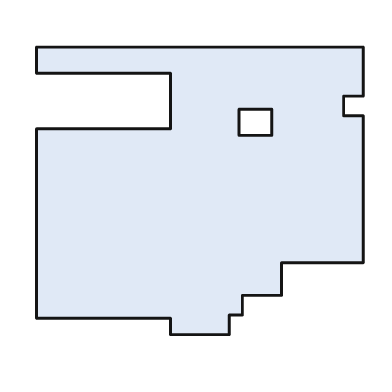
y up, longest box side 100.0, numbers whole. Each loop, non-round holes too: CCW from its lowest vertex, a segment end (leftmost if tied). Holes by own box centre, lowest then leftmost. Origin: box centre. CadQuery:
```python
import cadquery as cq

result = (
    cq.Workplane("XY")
    .moveTo(-9.0, -44.0)
    .lineTo(9.0, -44.0)
    .lineTo(9.0, -38.0)
    .lineTo(13.0, -38.0)
    .lineTo(13.0, -32.0)
    .lineTo(25.0, -32.0)
    .lineTo(25.0, -22.0)
    .lineTo(50.0, -22.0)
    .lineTo(50.0, 23.0)
    .lineTo(44.0, 23.0)
    .lineTo(44.0, 29.0)
    .lineTo(50.0, 29.0)
    .lineTo(50.0, 44.0)
    .lineTo(-50.0, 44.0)
    .lineTo(-50.0, 36.0)
    .lineTo(-9.0, 36.0)
    .lineTo(-9.0, 19.0)
    .lineTo(-50.0, 19.0)
    .lineTo(-50.0, -39.0)
    .lineTo(-9.0, -39.0)
    .close()
    .moveTo(12.0, 17.0)
    .lineTo(22.0, 17.0)
    .lineTo(22.0, 25.0)
    .lineTo(12.0, 25.0)
    .close()
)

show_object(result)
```